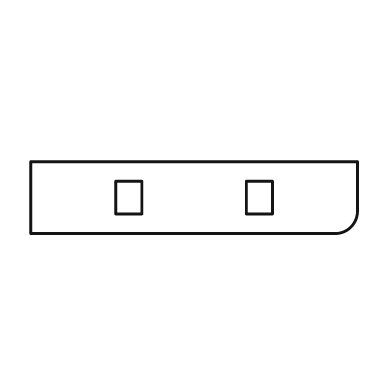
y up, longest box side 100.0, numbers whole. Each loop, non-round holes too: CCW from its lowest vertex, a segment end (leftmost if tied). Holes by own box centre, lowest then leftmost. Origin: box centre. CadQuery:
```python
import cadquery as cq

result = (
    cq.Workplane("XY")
    .moveTo(-50.0, -11.0)
    .lineTo(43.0, -11.0)
    .threePointArc((48.0, -9.0), (50.0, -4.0))
    .lineTo(50.0, 11.0)
    .lineTo(-50.0, 11.0)
    .close()
    .moveTo(-24.0, -5.0)
    .lineTo(-16.0, -5.0)
    .lineTo(-16.0, 5.0)
    .lineTo(-24.0, 5.0)
    .close()
    .moveTo(16.0, -5.0)
    .lineTo(24.0, -5.0)
    .lineTo(24.0, 5.0)
    .lineTo(16.0, 5.0)
    .close()
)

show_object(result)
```